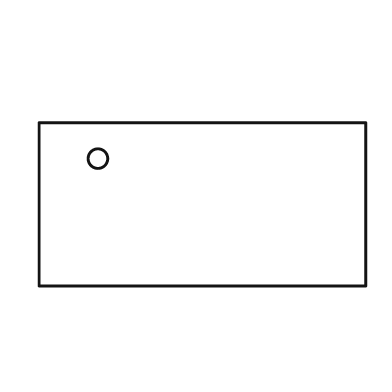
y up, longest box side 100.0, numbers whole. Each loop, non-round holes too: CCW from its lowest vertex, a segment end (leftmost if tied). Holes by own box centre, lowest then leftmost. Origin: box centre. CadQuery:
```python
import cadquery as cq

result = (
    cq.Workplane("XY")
    .moveTo(-50.0, -25.0)
    .lineTo(50.0, -25.0)
    .lineTo(50.0, 25.0)
    .lineTo(-50.0, 25.0)
    .close()
    .moveTo(-32.0, 14.0)
    .circle(3.0)
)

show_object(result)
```